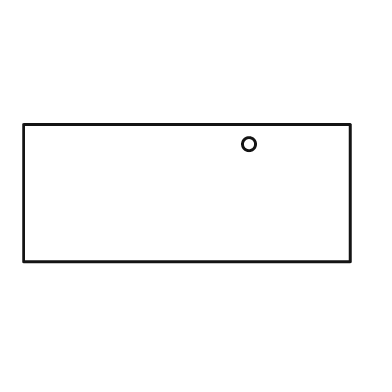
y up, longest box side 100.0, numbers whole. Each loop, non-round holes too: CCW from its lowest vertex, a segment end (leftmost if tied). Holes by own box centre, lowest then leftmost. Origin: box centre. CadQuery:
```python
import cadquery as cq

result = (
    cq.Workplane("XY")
    .moveTo(-50.0, -21.0)
    .lineTo(50.0, -21.0)
    .lineTo(50.0, 21.0)
    .lineTo(-50.0, 21.0)
    .close()
    .moveTo(19.0, 15.0)
    .circle(2.0)
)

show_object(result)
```